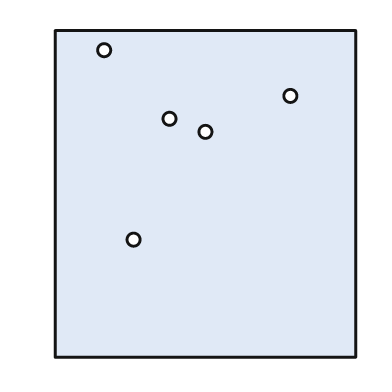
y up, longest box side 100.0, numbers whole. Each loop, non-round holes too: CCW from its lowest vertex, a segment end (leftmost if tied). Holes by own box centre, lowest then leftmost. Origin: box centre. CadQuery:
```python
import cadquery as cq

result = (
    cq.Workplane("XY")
    .moveTo(-46.0, -50.0)
    .lineTo(46.0, -50.0)
    .lineTo(46.0, 50.0)
    .lineTo(-46.0, 50.0)
    .close()
    .moveTo(-22.0, -14.0)
    .circle(2.0)
    .moveTo(0.0, 19.0)
    .circle(2.0)
    .moveTo(-11.0, 23.0)
    .circle(2.0)
    .moveTo(26.0, 30.0)
    .circle(2.0)
    .moveTo(-31.0, 44.0)
    .circle(2.0)
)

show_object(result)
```